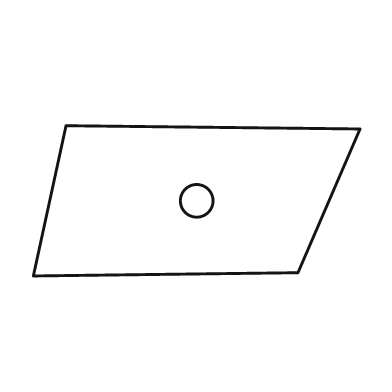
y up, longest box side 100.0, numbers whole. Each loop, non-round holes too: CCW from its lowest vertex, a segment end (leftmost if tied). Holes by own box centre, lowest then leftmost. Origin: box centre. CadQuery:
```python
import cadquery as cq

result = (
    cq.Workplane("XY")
    .moveTo(-50.0, -23.0)
    .lineTo(31.0, -22.0)
    .lineTo(50.0, 22.0)
    .lineTo(-40.0, 23.0)
    .close()
    .moveTo(0.0, 0.0)
    .circle(5.0)
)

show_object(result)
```